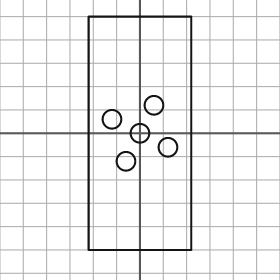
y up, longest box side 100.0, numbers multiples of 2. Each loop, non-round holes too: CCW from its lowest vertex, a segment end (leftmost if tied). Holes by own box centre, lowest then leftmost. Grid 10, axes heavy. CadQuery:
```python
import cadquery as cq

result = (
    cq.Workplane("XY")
    .moveTo(-22.0, -50.0)
    .lineTo(22.0, -50.0)
    .lineTo(22.0, 50.0)
    .lineTo(-22.0, 50.0)
    .close()
    .moveTo(-6.0, -12.0)
    .circle(4.0)
    .moveTo(12.0, -6.0)
    .circle(4.0)
    .moveTo(0.0, 0.0)
    .circle(4.0)
    .moveTo(-12.0, 6.0)
    .circle(4.0)
    .moveTo(6.0, 12.0)
    .circle(4.0)
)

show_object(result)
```